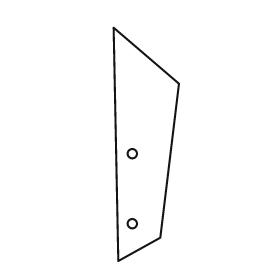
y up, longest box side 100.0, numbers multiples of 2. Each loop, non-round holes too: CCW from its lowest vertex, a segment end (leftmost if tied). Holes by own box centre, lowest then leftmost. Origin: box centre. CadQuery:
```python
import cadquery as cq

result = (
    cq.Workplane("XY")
    .moveTo(-12.0, -50.0)
    .lineTo(6.0, -40.0)
    .lineTo(14.0, 26.0)
    .lineTo(-14.0, 50.0)
    .close()
    .moveTo(-6.0, -34.0)
    .circle(2.0)
    .moveTo(-6.0, -4.0)
    .circle(2.0)
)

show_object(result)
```